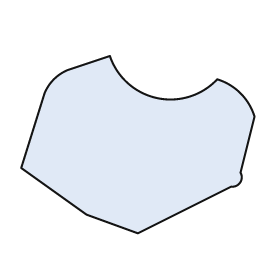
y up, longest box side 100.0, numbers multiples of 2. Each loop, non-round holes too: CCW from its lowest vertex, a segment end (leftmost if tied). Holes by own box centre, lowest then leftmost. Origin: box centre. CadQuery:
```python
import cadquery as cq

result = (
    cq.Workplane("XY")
    .moveTo(0.0, -38.0)
    .lineTo(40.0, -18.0)
    .threePointArc((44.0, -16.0), (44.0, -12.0))
    .lineTo(50.0, 12.0)
    .threePointArc((44.0, 22.0), (34.0, 28.0))
    .threePointArc((8.0, 20.0), (-12.0, 38.0))
    .lineTo(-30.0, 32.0)
    .threePointArc((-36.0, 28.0), (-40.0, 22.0))
    .lineTo(-50.0, -10.0)
    .lineTo(-22.0, -30.0)
    .close()
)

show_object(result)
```